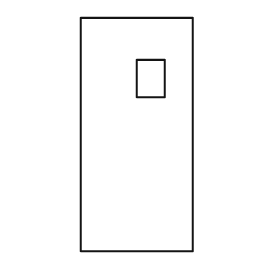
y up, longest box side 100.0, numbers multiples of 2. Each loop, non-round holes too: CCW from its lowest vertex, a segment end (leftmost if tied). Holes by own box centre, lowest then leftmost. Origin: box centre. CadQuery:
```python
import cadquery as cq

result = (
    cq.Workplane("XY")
    .moveTo(-24.0, -50.0)
    .lineTo(24.0, -50.0)
    .lineTo(24.0, 50.0)
    .lineTo(-24.0, 50.0)
    .close()
    .moveTo(0.0, 16.0)
    .lineTo(12.0, 16.0)
    .lineTo(12.0, 32.0)
    .lineTo(0.0, 32.0)
    .close()
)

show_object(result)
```